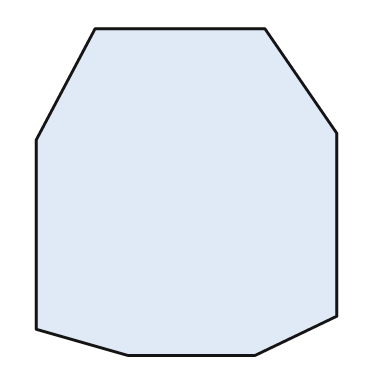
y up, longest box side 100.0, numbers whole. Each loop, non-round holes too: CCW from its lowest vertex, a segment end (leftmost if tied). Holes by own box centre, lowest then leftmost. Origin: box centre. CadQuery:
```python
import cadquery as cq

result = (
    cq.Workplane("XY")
    .moveTo(-18.0, -50.0)
    .lineTo(21.0, -50.0)
    .lineTo(46.0, -38.0)
    .lineTo(46.0, 18.0)
    .lineTo(24.0, 50.0)
    .lineTo(-28.0, 50.0)
    .lineTo(-46.0, 16.0)
    .lineTo(-46.0, -42.0)
    .close()
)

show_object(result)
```